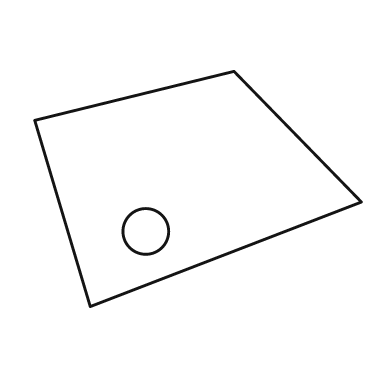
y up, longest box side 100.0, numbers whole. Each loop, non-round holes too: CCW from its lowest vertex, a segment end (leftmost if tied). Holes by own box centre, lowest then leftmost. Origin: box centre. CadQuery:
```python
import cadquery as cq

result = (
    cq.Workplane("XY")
    .moveTo(-33.0, -36.0)
    .lineTo(50.0, -4.0)
    .lineTo(11.0, 36.0)
    .lineTo(-50.0, 21.0)
    .close()
    .moveTo(-16.0, -13.0)
    .circle(7.0)
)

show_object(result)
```